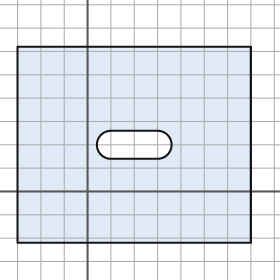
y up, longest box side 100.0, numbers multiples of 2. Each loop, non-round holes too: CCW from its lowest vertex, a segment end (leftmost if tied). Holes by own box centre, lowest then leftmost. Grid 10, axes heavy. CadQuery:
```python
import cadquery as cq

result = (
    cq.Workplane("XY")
    .moveTo(-30.0, -22.0)
    .lineTo(70.0, -22.0)
    .lineTo(70.0, 62.0)
    .lineTo(-30.0, 62.0)
    .close()
    .moveTo(10.0, 14.0)
    .lineTo(30.0, 14.0)
    .threePointArc((36.0, 20.0), (30.0, 26.0))
    .lineTo(10.0, 26.0)
    .threePointArc((4.0, 20.0), (10.0, 14.0))
    .close()
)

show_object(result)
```